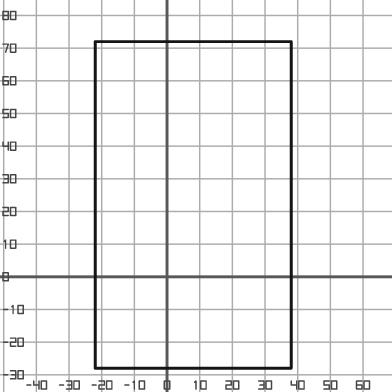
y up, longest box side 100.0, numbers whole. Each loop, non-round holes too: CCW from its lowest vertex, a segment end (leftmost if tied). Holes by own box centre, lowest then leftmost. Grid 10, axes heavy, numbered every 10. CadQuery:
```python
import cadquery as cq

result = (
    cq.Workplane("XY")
    .moveTo(-22.0, -28.0)
    .lineTo(38.0, -28.0)
    .lineTo(38.0, 72.0)
    .lineTo(-22.0, 72.0)
    .close()
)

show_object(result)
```